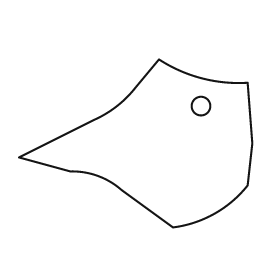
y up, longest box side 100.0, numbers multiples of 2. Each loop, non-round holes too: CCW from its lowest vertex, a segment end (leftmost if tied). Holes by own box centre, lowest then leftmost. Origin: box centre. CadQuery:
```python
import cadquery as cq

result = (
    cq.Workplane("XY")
    .moveTo(16.0, -36.0)
    .threePointArc((34.0, -30.0), (48.0, -18.0))
    .lineTo(50.0, 0.0)
    .lineTo(48.0, 26.0)
    .threePointArc((28.0, 28.0), (10.0, 36.0))
    .lineTo(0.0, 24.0)
    .threePointArc((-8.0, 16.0), (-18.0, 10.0))
    .lineTo(-50.0, -6.0)
    .lineTo(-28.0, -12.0)
    .threePointArc((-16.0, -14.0), (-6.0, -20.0))
    .close()
    .moveTo(28.0, 16.0)
    .circle(4.0)
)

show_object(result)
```